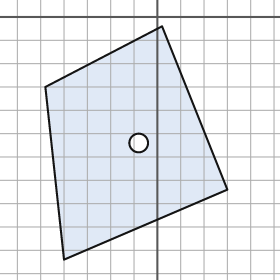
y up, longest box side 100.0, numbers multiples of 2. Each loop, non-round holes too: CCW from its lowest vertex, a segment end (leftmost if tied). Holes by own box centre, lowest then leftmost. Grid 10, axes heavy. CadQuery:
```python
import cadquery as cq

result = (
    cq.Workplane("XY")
    .moveTo(-40.0, -104.0)
    .lineTo(30.0, -74.0)
    .lineTo(2.0, -4.0)
    .lineTo(-48.0, -30.0)
    .close()
    .moveTo(-8.0, -54.0)
    .circle(4.0)
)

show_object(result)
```